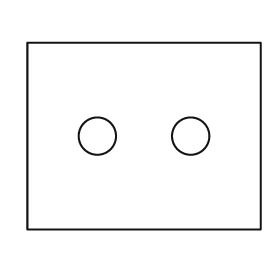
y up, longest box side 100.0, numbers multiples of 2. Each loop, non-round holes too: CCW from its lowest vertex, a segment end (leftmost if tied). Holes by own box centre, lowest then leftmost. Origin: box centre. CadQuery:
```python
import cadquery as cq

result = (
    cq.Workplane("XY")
    .moveTo(-50.0, -40.0)
    .lineTo(50.0, -40.0)
    .lineTo(50.0, 40.0)
    .lineTo(-50.0, 40.0)
    .close()
    .moveTo(-20.0, 0.0)
    .circle(8.0)
    .moveTo(20.0, 0.0)
    .circle(8.0)
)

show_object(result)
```